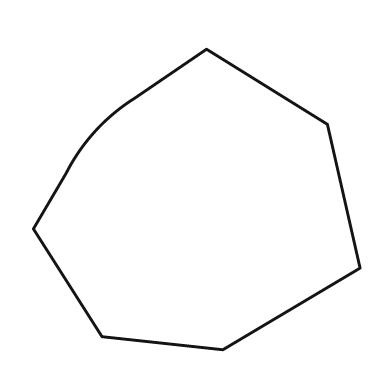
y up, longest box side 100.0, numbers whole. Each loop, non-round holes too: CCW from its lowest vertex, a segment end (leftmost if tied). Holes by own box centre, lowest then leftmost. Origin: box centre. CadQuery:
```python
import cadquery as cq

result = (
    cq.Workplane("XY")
    .moveTo(8.0, -46.0)
    .lineTo(50.0, -21.0)
    .lineTo(40.0, 23.0)
    .lineTo(3.0, 46.0)
    .lineTo(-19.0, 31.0)
    .threePointArc((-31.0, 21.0), (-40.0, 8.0))
    .lineTo(-50.0, -9.0)
    .lineTo(-29.0, -42.0)
    .close()
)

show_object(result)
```